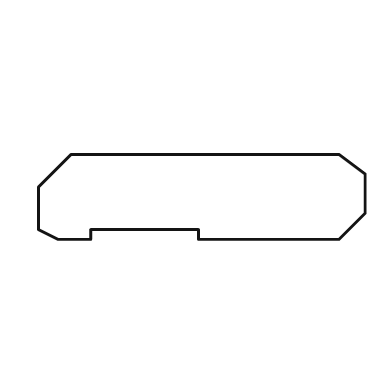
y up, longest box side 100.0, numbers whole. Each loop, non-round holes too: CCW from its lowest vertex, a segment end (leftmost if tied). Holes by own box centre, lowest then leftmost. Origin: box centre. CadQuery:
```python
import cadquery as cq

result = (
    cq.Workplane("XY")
    .moveTo(-44.0, -13.0)
    .lineTo(-34.0, -13.0)
    .lineTo(-34.0, -10.0)
    .lineTo(-1.0, -10.0)
    .lineTo(-1.0, -13.0)
    .lineTo(42.0, -13.0)
    .lineTo(50.0, -5.0)
    .lineTo(50.0, 7.0)
    .lineTo(42.0, 13.0)
    .lineTo(-40.0, 13.0)
    .lineTo(-50.0, 3.0)
    .lineTo(-50.0, -10.0)
    .close()
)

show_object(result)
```